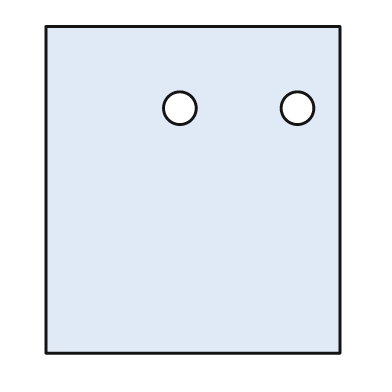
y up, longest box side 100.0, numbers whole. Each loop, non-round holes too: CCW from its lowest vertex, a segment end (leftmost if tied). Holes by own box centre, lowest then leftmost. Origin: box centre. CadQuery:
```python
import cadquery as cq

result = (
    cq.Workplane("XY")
    .moveTo(-45.0, -50.0)
    .lineTo(45.0, -50.0)
    .lineTo(45.0, 50.0)
    .lineTo(-45.0, 50.0)
    .close()
    .moveTo(-4.0, 25.0)
    .circle(5.0)
    .moveTo(32.0, 25.0)
    .circle(5.0)
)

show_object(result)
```